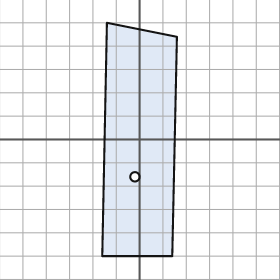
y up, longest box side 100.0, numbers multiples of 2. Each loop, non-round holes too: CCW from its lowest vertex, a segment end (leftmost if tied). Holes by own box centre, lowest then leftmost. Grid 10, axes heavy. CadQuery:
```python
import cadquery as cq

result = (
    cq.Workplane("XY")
    .moveTo(-16.0, -50.0)
    .lineTo(14.0, -50.0)
    .lineTo(16.0, 44.0)
    .lineTo(-14.0, 50.0)
    .close()
    .moveTo(-2.0, -16.0)
    .circle(2.0)
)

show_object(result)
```